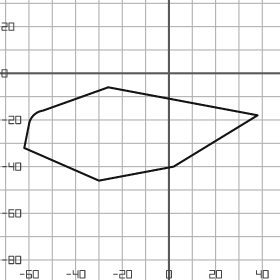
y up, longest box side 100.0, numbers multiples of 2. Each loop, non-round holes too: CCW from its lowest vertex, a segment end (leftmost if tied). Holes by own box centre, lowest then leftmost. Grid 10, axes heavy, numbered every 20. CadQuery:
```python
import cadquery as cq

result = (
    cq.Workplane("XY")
    .moveTo(-30.0, -46.0)
    .lineTo(2.0, -40.0)
    .lineTo(38.0, -18.0)
    .lineTo(-26.0, -6.0)
    .lineTo(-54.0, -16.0)
    .threePointArc((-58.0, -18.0), (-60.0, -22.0))
    .lineTo(-62.0, -32.0)
    .close()
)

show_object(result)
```